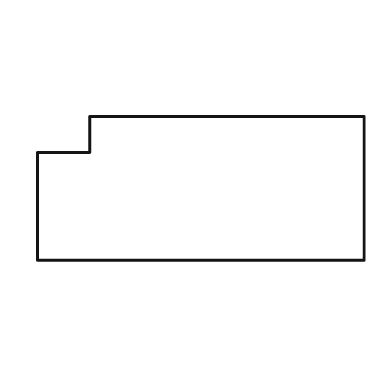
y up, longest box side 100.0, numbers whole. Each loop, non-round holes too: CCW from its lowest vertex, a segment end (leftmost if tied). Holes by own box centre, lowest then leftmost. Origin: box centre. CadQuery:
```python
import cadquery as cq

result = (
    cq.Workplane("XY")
    .moveTo(-50.0, -22.0)
    .lineTo(50.0, -22.0)
    .lineTo(50.0, 22.0)
    .lineTo(-34.0, 22.0)
    .lineTo(-34.0, 11.0)
    .lineTo(-50.0, 11.0)
    .close()
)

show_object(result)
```